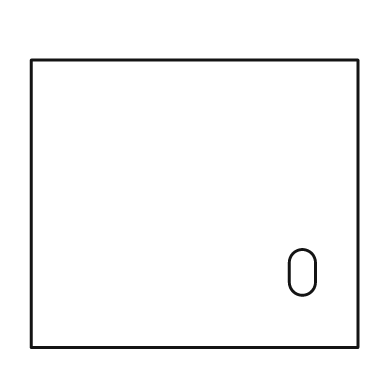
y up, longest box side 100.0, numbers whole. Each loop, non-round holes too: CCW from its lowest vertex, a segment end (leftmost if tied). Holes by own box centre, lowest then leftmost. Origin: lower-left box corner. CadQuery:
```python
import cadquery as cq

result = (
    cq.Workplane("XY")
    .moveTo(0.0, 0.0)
    .lineTo(100.0, 0.0)
    .lineTo(100.0, 88.0)
    .lineTo(0.0, 88.0)
    .close()
    .moveTo(79.0, 20.0)
    .threePointArc((83.0, 16.0), (87.0, 20.0))
    .lineTo(87.0, 26.0)
    .threePointArc((83.0, 30.0), (79.0, 26.0))
    .close()
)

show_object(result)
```